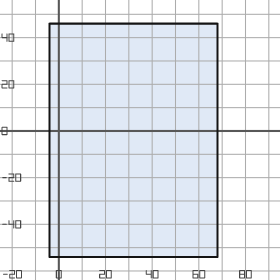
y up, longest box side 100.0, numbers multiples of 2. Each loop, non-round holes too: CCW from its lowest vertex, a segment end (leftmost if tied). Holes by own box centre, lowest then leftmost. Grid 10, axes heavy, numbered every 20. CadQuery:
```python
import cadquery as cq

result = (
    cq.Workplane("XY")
    .moveTo(-4.0, -54.0)
    .lineTo(68.0, -54.0)
    .lineTo(68.0, 46.0)
    .lineTo(-4.0, 46.0)
    .close()
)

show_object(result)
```